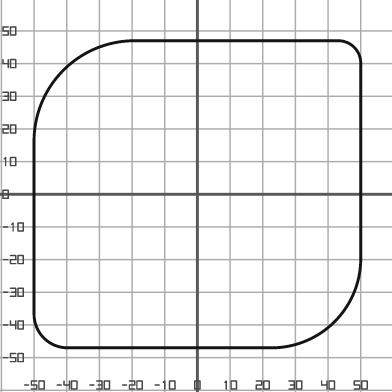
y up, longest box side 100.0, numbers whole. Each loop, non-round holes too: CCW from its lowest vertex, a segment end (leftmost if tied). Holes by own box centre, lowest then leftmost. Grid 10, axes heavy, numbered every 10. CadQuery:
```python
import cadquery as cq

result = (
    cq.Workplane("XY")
    .moveTo(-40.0, -47.0)
    .lineTo(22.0, -47.0)
    .threePointArc((42.0, -39.0), (50.0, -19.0))
    .lineTo(50.0, 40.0)
    .threePointArc((48.0, 45.0), (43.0, 47.0))
    .lineTo(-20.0, 47.0)
    .threePointArc((-41.0, 38.0), (-50.0, 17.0))
    .lineTo(-50.0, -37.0)
    .threePointArc((-47.0, -44.0), (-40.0, -47.0))
    .close()
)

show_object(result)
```